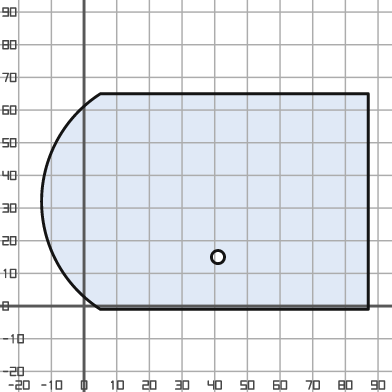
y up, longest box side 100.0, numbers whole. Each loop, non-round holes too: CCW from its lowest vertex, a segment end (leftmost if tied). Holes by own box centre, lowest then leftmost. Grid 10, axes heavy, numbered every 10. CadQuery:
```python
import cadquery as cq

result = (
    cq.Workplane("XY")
    .moveTo(5.0, -1.0)
    .lineTo(87.0, -1.0)
    .lineTo(87.0, 65.0)
    .lineTo(5.0, 65.0)
    .threePointArc((-13.0, 32.0), (5.0, -1.0))
    .close()
    .moveTo(41.0, 15.0)
    .circle(2.0)
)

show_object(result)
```